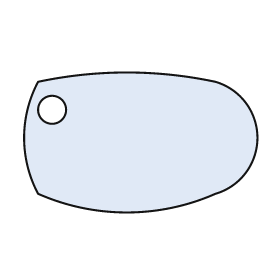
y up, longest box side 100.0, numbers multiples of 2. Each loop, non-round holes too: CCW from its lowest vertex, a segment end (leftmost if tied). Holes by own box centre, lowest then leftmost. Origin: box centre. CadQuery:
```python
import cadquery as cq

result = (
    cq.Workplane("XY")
    .moveTo(-44.0, -22.0)
    .threePointArc((-6.0, -30.0), (32.0, -22.0))
    .threePointArc((50.0, 2.0), (32.0, 26.0))
    .threePointArc((-6.0, 30.0), (-44.0, 26.0))
    .threePointArc((-50.0, 2.0), (-44.0, -22.0))
    .close()
    .moveTo(-38.0, 14.0)
    .circle(6.0)
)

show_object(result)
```